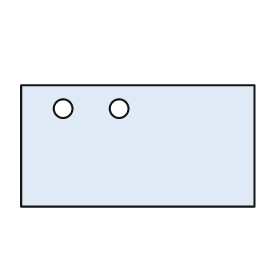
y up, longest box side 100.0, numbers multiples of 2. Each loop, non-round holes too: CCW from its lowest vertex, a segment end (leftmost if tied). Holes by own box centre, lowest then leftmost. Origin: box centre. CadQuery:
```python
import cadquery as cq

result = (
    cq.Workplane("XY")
    .moveTo(-50.0, -26.0)
    .lineTo(50.0, -26.0)
    .lineTo(50.0, 26.0)
    .lineTo(-50.0, 26.0)
    .close()
    .moveTo(-32.0, 16.0)
    .circle(4.0)
    .moveTo(-8.0, 16.0)
    .circle(4.0)
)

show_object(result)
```